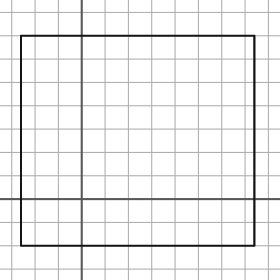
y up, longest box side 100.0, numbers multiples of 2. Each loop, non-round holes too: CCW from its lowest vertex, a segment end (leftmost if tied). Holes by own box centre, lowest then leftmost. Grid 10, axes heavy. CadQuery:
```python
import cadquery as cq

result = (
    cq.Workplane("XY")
    .moveTo(-26.0, -20.0)
    .lineTo(74.0, -20.0)
    .lineTo(74.0, 70.0)
    .lineTo(-26.0, 70.0)
    .close()
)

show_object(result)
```